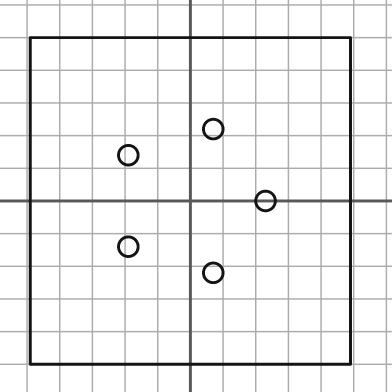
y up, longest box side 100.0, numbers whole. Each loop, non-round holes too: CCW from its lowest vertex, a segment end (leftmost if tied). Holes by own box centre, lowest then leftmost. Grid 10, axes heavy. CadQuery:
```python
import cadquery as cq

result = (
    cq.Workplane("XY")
    .moveTo(-49.0, -50.0)
    .lineTo(49.0, -50.0)
    .lineTo(49.0, 50.0)
    .lineTo(-49.0, 50.0)
    .close()
    .moveTo(7.0, -22.0)
    .circle(3.0)
    .moveTo(-19.0, -14.0)
    .circle(3.0)
    .moveTo(23.0, 0.0)
    .circle(3.0)
    .moveTo(-19.0, 14.0)
    .circle(3.0)
    .moveTo(7.0, 22.0)
    .circle(3.0)
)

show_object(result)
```